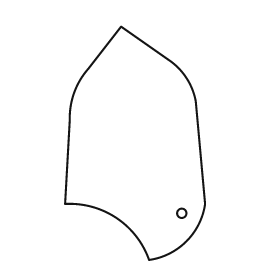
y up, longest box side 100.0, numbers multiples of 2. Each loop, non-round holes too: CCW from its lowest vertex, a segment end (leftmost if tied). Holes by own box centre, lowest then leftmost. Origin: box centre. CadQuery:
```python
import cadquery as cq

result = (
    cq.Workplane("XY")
    .moveTo(6.0, -50.0)
    .threePointArc((22.0, -42.0), (30.0, -26.0))
    .lineTo(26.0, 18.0)
    .threePointArc((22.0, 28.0), (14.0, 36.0))
    .lineTo(-6.0, 50.0)
    .lineTo(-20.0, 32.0)
    .threePointArc((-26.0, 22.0), (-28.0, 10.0))
    .lineTo(-30.0, -26.0)
    .threePointArc((-8.0, -32.0), (6.0, -50.0))
    .close()
    .moveTo(20.0, -30.0)
    .circle(2.0)
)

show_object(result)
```